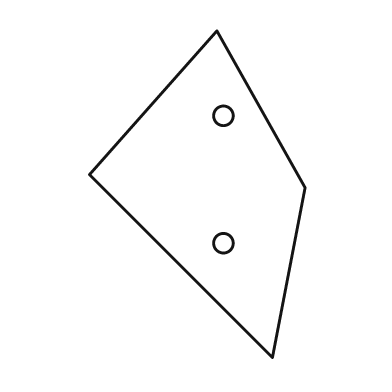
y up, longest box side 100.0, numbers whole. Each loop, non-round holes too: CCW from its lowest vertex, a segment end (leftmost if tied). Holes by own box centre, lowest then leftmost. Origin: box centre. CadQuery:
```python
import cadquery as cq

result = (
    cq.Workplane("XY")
    .moveTo(23.0, -50.0)
    .lineTo(33.0, 2.0)
    .lineTo(6.0, 50.0)
    .lineTo(-33.0, 6.0)
    .close()
    .moveTo(8.0, -15.0)
    .circle(3.0)
    .moveTo(8.0, 24.0)
    .circle(3.0)
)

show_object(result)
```